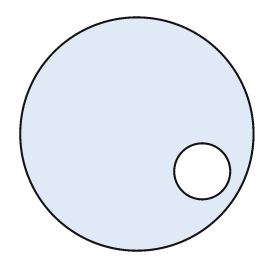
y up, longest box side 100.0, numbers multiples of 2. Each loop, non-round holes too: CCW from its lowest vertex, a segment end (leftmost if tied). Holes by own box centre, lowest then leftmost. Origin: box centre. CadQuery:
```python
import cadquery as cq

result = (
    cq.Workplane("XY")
    .moveTo(0.0, 0.0)
    .circle(50.0)
    .moveTo(28.0, -16.0)
    .circle(12.0)
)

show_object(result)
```